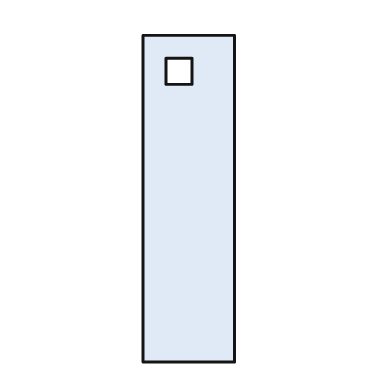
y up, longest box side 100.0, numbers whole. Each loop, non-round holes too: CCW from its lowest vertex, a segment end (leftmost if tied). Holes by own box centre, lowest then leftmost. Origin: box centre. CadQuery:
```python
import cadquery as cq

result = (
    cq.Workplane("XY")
    .moveTo(-14.0, -50.0)
    .lineTo(14.0, -50.0)
    .lineTo(14.0, 50.0)
    .lineTo(-14.0, 50.0)
    .close()
    .moveTo(-7.0, 35.0)
    .lineTo(1.0, 35.0)
    .lineTo(1.0, 43.0)
    .lineTo(-7.0, 43.0)
    .close()
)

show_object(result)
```